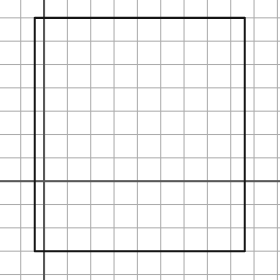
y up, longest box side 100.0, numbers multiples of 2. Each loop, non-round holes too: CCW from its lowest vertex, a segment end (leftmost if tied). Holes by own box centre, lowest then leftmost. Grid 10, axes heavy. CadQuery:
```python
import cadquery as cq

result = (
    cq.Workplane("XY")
    .moveTo(-4.0, -30.0)
    .lineTo(86.0, -30.0)
    .lineTo(86.0, 70.0)
    .lineTo(-4.0, 70.0)
    .close()
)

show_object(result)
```